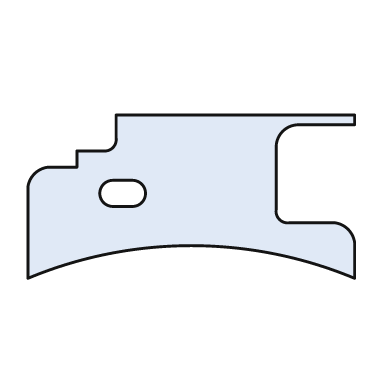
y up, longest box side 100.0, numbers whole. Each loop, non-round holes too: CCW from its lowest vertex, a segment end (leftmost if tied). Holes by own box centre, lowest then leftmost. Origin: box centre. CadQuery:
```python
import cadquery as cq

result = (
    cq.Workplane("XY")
    .moveTo(-50.0, -25.0)
    .threePointArc((0.0, -15.0), (50.0, -25.0))
    .lineTo(50.0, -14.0)
    .threePointArc((48.0, -10.0), (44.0, -8.0))
    .lineTo(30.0, -8.0)
    .threePointArc((27.0, -7.0), (26.0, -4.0))
    .lineTo(26.0, 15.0)
    .threePointArc((28.0, 20.0), (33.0, 22.0))
    .lineTo(50.0, 22.0)
    .lineTo(50.0, 25.0)
    .lineTo(-23.0, 25.0)
    .lineTo(-23.0, 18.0)
    .threePointArc((-24.0, 15.0), (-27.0, 14.0))
    .lineTo(-35.0, 14.0)
    .lineTo(-35.0, 9.0)
    .lineTo(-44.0, 9.0)
    .threePointArc((-48.0, 7.0), (-50.0, 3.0))
    .close()
    .moveTo(-24.0, -3.0)
    .lineTo(-18.0, -3.0)
    .threePointArc((-14.0, 1.0), (-18.0, 5.0))
    .lineTo(-24.0, 5.0)
    .threePointArc((-28.0, 1.0), (-24.0, -3.0))
    .close()
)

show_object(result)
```